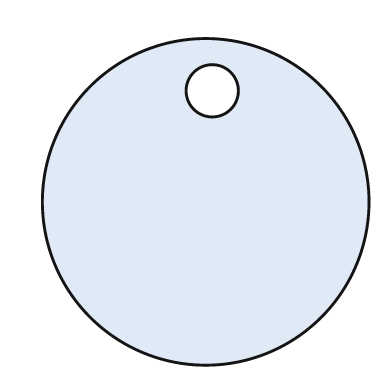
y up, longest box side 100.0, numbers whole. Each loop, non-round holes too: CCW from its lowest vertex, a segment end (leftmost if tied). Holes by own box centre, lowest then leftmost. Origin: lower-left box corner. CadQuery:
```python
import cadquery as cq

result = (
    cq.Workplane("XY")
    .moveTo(50.0, 50.0)
    .circle(50.0)
    .moveTo(52.0, 84.0)
    .circle(8.0)
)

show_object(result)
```